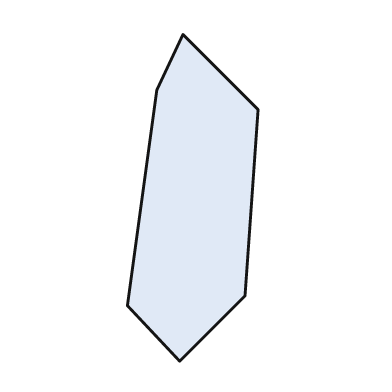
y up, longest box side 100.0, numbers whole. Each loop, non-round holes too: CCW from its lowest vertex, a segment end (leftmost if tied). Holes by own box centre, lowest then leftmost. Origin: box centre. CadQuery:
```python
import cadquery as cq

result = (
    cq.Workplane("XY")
    .moveTo(-4.0, -50.0)
    .lineTo(16.0, -30.0)
    .lineTo(20.0, 27.0)
    .lineTo(-3.0, 50.0)
    .lineTo(-11.0, 33.0)
    .lineTo(-20.0, -33.0)
    .close()
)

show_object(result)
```